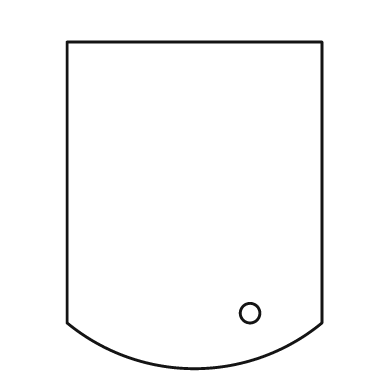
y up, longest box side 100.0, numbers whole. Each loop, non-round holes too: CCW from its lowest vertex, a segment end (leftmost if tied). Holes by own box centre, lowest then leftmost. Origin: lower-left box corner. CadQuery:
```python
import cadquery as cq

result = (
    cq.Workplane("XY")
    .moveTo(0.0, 14.0)
    .threePointArc((39.0, 0.0), (78.0, 14.0))
    .lineTo(78.0, 100.0)
    .lineTo(0.0, 100.0)
    .close()
    .moveTo(56.0, 17.0)
    .circle(3.0)
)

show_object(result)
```